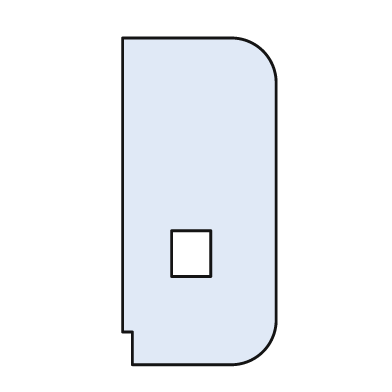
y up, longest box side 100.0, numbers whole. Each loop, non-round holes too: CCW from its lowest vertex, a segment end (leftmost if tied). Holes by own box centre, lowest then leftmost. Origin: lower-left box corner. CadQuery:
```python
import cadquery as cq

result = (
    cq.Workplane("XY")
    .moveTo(3.0, 0.0)
    .lineTo(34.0, 0.0)
    .threePointArc((43.0, 4.0), (47.0, 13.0))
    .lineTo(47.0, 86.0)
    .threePointArc((43.0, 96.0), (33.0, 100.0))
    .lineTo(0.0, 100.0)
    .lineTo(0.0, 10.0)
    .lineTo(3.0, 10.0)
    .close()
    .moveTo(15.0, 27.0)
    .lineTo(27.0, 27.0)
    .lineTo(27.0, 41.0)
    .lineTo(15.0, 41.0)
    .close()
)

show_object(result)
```